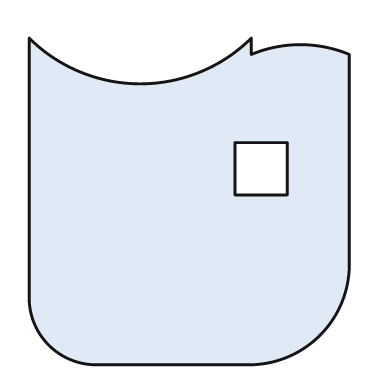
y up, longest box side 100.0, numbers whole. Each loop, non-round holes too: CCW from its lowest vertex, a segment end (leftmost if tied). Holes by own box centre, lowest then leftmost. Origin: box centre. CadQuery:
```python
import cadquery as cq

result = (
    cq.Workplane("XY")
    .moveTo(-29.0, -50.0)
    .lineTo(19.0, -50.0)
    .threePointArc((40.0, -41.0), (49.0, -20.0))
    .lineTo(49.0, 45.0)
    .threePointArc((34.0, 48.0), (19.0, 45.0))
    .lineTo(19.0, 50.0)
    .threePointArc((-15.0, 36.0), (-49.0, 50.0))
    .lineTo(-49.0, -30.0)
    .threePointArc((-43.0, -44.0), (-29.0, -50.0))
    .close()
    .moveTo(14.0, 2.0)
    .lineTo(30.0, 2.0)
    .lineTo(30.0, 18.0)
    .lineTo(14.0, 18.0)
    .close()
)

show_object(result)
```